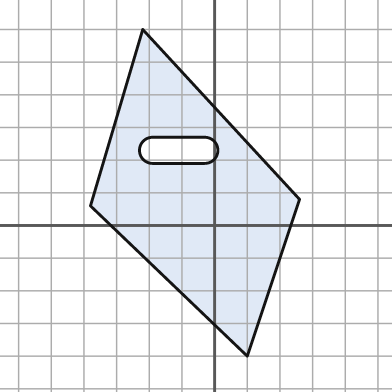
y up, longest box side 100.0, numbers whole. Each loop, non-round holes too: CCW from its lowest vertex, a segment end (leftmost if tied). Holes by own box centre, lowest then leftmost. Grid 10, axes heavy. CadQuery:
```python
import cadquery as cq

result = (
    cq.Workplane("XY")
    .moveTo(10.0, -40.0)
    .lineTo(26.0, 8.0)
    .lineTo(-22.0, 60.0)
    .lineTo(-38.0, 6.0)
    .close()
    .moveTo(-19.0, 19.0)
    .lineTo(-3.0, 19.0)
    .threePointArc((1.0, 23.0), (-3.0, 27.0))
    .lineTo(-19.0, 27.0)
    .threePointArc((-23.0, 23.0), (-19.0, 19.0))
    .close()
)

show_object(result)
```